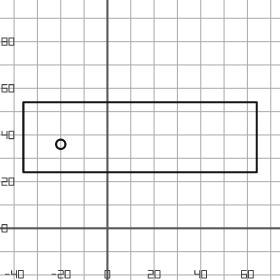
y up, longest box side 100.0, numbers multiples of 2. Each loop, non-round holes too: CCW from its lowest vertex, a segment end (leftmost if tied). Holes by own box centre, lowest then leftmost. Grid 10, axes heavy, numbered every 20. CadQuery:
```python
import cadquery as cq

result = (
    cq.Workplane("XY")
    .moveTo(-36.0, 24.0)
    .lineTo(64.0, 24.0)
    .lineTo(64.0, 54.0)
    .lineTo(-36.0, 54.0)
    .close()
    .moveTo(-20.0, 36.0)
    .circle(2.0)
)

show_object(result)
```